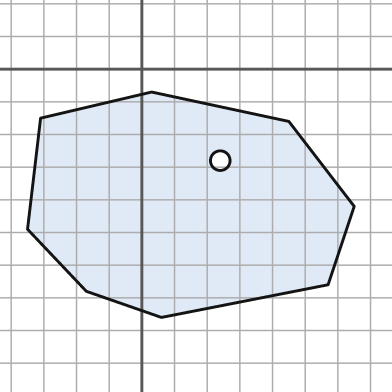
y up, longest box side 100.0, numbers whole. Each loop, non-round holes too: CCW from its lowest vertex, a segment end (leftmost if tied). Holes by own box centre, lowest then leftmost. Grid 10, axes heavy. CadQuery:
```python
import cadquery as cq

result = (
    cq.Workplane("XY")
    .moveTo(6.0, -76.0)
    .lineTo(57.0, -66.0)
    .lineTo(65.0, -42.0)
    .lineTo(45.0, -16.0)
    .lineTo(3.0, -7.0)
    .lineTo(-31.0, -15.0)
    .lineTo(-35.0, -49.0)
    .lineTo(-17.0, -68.0)
    .close()
    .moveTo(24.0, -28.0)
    .circle(3.0)
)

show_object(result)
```